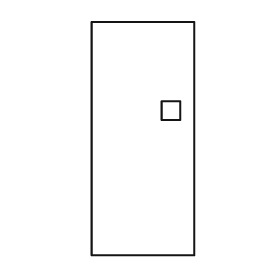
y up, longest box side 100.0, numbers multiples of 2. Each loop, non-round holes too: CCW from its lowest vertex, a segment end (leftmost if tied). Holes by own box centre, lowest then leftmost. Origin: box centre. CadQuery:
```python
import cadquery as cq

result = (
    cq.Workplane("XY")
    .moveTo(-22.0, -50.0)
    .lineTo(22.0, -50.0)
    .lineTo(22.0, 50.0)
    .lineTo(-22.0, 50.0)
    .close()
    .moveTo(8.0, 8.0)
    .lineTo(16.0, 8.0)
    .lineTo(16.0, 16.0)
    .lineTo(8.0, 16.0)
    .close()
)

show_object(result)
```